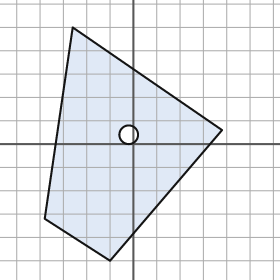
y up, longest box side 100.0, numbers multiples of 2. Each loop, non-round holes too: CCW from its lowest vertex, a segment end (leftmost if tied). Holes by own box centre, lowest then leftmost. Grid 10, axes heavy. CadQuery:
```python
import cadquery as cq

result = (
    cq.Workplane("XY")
    .moveTo(-10.0, -50.0)
    .lineTo(38.0, 6.0)
    .lineTo(-26.0, 50.0)
    .lineTo(-38.0, -32.0)
    .close()
    .moveTo(-2.0, 4.0)
    .circle(4.0)
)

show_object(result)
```